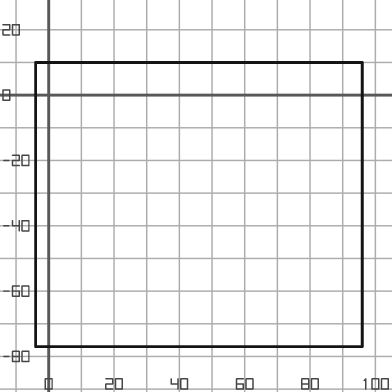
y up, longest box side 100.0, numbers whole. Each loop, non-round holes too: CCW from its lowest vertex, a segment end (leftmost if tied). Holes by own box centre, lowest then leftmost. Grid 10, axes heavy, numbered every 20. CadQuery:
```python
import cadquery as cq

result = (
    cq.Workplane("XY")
    .moveTo(-4.0, -77.0)
    .lineTo(96.0, -77.0)
    .lineTo(96.0, 10.0)
    .lineTo(-4.0, 10.0)
    .close()
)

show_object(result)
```